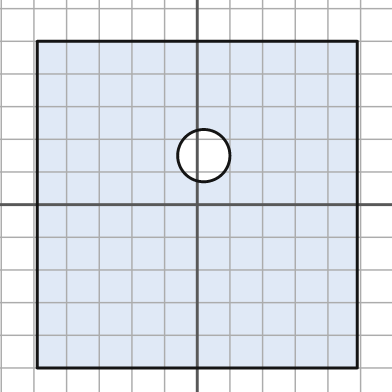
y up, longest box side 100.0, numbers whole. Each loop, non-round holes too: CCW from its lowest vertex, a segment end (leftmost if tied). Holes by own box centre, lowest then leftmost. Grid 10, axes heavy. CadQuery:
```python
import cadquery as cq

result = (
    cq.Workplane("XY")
    .moveTo(-49.0, -50.0)
    .lineTo(49.0, -50.0)
    .lineTo(49.0, 50.0)
    .lineTo(-49.0, 50.0)
    .close()
    .moveTo(2.0, 15.0)
    .circle(8.0)
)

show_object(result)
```